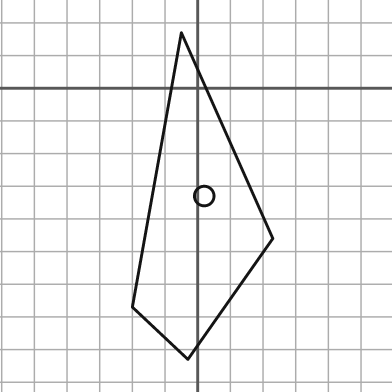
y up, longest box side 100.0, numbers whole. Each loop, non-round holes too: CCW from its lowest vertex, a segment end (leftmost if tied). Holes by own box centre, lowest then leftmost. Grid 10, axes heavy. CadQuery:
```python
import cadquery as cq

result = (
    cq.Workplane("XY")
    .moveTo(-3.0, -83.0)
    .lineTo(23.0, -46.0)
    .lineTo(-5.0, 17.0)
    .lineTo(-20.0, -67.0)
    .close()
    .moveTo(2.0, -33.0)
    .circle(3.0)
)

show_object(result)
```